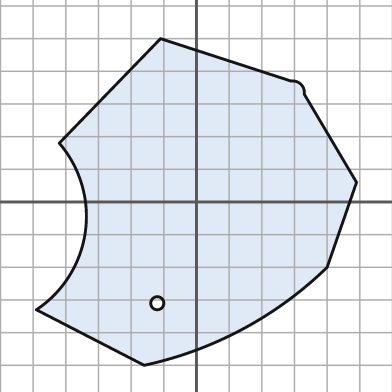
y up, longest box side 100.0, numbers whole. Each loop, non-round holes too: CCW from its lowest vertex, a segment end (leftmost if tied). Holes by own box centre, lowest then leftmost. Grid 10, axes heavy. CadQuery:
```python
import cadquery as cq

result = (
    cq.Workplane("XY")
    .moveTo(-16.0, -50.0)
    .threePointArc((14.0, -39.0), (40.0, -20.0))
    .lineTo(49.0, 6.0)
    .lineTo(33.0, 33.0)
    .threePointArc((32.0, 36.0), (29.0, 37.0))
    .lineTo(-11.0, 50.0)
    .lineTo(-42.0, 18.0)
    .threePointArc((-34.0, -9.0), (-49.0, -33.0))
    .close()
    .moveTo(-12.0, -31.0)
    .circle(2.0)
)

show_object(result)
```